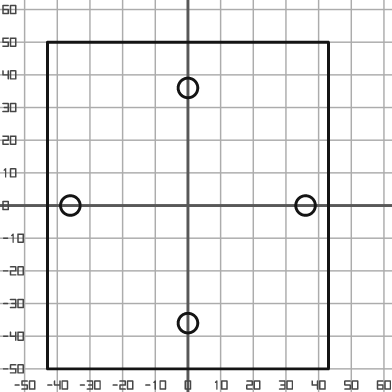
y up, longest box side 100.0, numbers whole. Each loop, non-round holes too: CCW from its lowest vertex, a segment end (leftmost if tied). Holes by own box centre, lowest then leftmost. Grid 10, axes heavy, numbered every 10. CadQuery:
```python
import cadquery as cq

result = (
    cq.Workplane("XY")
    .moveTo(-43.0, -50.0)
    .lineTo(43.0, -50.0)
    .lineTo(43.0, 50.0)
    .lineTo(-43.0, 50.0)
    .close()
    .moveTo(0.0, -36.0)
    .circle(3.0)
    .moveTo(-36.0, 0.0)
    .circle(3.0)
    .moveTo(36.0, 0.0)
    .circle(3.0)
    .moveTo(0.0, 36.0)
    .circle(3.0)
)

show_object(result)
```